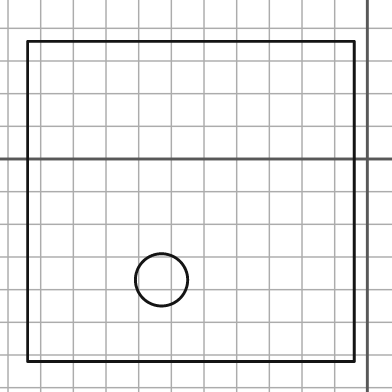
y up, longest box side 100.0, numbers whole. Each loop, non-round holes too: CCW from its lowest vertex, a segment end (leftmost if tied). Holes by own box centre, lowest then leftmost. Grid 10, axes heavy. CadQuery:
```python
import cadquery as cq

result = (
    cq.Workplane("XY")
    .moveTo(-104.0, -62.0)
    .lineTo(-4.0, -62.0)
    .lineTo(-4.0, 36.0)
    .lineTo(-104.0, 36.0)
    .close()
    .moveTo(-63.0, -37.0)
    .circle(8.0)
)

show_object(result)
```